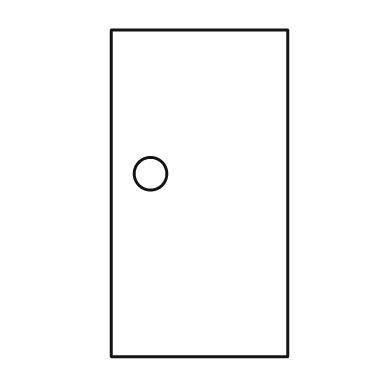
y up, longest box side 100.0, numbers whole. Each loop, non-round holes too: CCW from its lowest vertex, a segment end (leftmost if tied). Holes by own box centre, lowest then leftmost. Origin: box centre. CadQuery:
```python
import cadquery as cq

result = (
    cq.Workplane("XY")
    .moveTo(-27.0, -50.0)
    .lineTo(27.0, -50.0)
    .lineTo(27.0, 50.0)
    .lineTo(-27.0, 50.0)
    .close()
    .moveTo(-15.0, 6.0)
    .circle(5.0)
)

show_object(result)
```